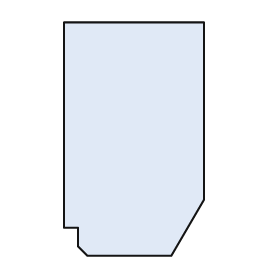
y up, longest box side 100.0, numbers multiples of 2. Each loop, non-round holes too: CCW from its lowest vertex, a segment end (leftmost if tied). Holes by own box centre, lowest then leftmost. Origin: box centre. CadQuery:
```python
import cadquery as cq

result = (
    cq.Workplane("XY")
    .moveTo(-20.0, -50.0)
    .lineTo(16.0, -50.0)
    .lineTo(30.0, -26.0)
    .lineTo(30.0, 50.0)
    .lineTo(-30.0, 50.0)
    .lineTo(-30.0, -38.0)
    .lineTo(-24.0, -38.0)
    .lineTo(-24.0, -46.0)
    .close()
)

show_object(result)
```